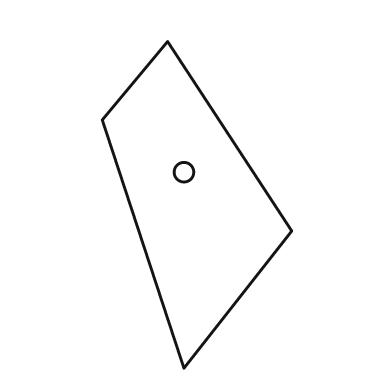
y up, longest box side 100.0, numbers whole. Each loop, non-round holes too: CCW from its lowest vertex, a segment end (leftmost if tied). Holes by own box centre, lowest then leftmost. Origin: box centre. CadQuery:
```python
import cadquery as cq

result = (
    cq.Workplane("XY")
    .moveTo(-4.0, -50.0)
    .lineTo(29.0, -8.0)
    .lineTo(-9.0, 50.0)
    .lineTo(-29.0, 26.0)
    .close()
    .moveTo(-4.0, 10.0)
    .circle(3.0)
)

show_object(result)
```